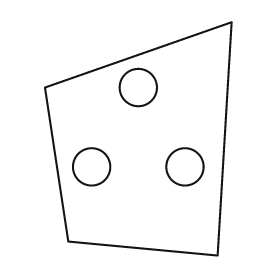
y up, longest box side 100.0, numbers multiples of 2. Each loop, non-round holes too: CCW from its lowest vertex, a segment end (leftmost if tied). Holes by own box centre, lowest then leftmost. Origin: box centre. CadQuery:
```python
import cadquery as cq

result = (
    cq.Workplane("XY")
    .moveTo(34.0, -50.0)
    .lineTo(40.0, 50.0)
    .lineTo(-40.0, 22.0)
    .lineTo(-30.0, -44.0)
    .close()
    .moveTo(-20.0, -12.0)
    .circle(8.0)
    .moveTo(20.0, -12.0)
    .circle(8.0)
    .moveTo(0.0, 22.0)
    .circle(8.0)
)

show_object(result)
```